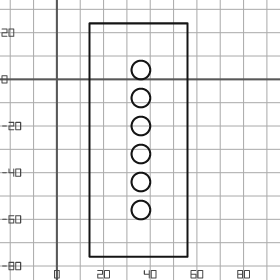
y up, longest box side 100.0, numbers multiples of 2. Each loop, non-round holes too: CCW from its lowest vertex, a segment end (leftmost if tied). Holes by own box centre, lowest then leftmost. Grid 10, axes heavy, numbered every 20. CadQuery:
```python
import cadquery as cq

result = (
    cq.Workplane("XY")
    .moveTo(14.0, -76.0)
    .lineTo(56.0, -76.0)
    .lineTo(56.0, 24.0)
    .lineTo(14.0, 24.0)
    .close()
    .moveTo(36.0, -56.0)
    .circle(4.0)
    .moveTo(36.0, -44.0)
    .circle(4.0)
    .moveTo(36.0, -32.0)
    .circle(4.0)
    .moveTo(36.0, -20.0)
    .circle(4.0)
    .moveTo(36.0, -8.0)
    .circle(4.0)
    .moveTo(36.0, 4.0)
    .circle(4.0)
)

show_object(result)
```